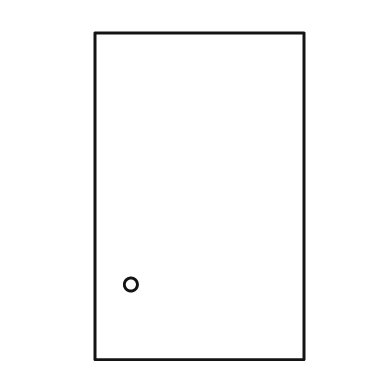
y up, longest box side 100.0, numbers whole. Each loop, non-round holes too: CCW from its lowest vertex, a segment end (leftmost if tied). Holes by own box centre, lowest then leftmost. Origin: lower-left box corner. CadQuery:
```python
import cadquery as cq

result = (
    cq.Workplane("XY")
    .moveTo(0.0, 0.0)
    .lineTo(64.0, 0.0)
    .lineTo(64.0, 100.0)
    .lineTo(0.0, 100.0)
    .close()
    .moveTo(11.0, 23.0)
    .circle(2.0)
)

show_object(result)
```